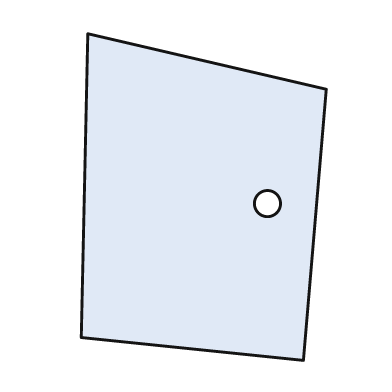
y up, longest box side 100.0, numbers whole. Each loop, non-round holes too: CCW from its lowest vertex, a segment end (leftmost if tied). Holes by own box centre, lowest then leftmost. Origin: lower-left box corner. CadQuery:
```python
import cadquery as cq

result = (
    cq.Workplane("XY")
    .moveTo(68.0, 0.0)
    .lineTo(75.0, 83.0)
    .lineTo(2.0, 100.0)
    .lineTo(0.0, 7.0)
    .close()
    .moveTo(57.0, 48.0)
    .circle(4.0)
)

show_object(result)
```